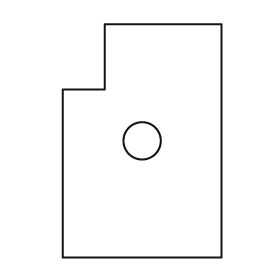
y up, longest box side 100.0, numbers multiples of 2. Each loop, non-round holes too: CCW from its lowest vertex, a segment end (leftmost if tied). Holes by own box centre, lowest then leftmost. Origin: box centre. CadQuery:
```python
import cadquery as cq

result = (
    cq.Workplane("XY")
    .moveTo(-34.0, -50.0)
    .lineTo(34.0, -50.0)
    .lineTo(34.0, 50.0)
    .lineTo(-16.0, 50.0)
    .lineTo(-16.0, 22.0)
    .lineTo(-34.0, 22.0)
    .close()
    .moveTo(0.0, 0.0)
    .circle(8.0)
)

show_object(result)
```